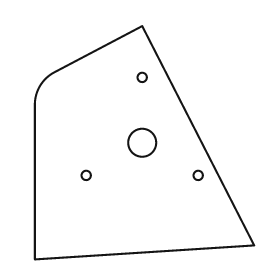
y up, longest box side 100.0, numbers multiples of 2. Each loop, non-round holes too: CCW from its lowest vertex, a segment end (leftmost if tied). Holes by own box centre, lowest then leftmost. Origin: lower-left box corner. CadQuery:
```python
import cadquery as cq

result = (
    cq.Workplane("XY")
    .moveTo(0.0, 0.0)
    .lineTo(94.0, 6.0)
    .lineTo(46.0, 100.0)
    .lineTo(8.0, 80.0)
    .threePointArc((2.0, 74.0), (0.0, 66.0))
    .close()
    .moveTo(22.0, 36.0)
    .circle(2.0)
    .moveTo(70.0, 36.0)
    .circle(2.0)
    .moveTo(46.0, 50.0)
    .circle(6.0)
    .moveTo(46.0, 78.0)
    .circle(2.0)
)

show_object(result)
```